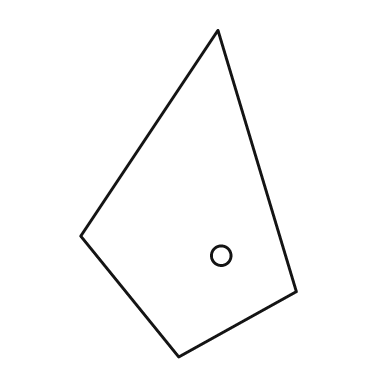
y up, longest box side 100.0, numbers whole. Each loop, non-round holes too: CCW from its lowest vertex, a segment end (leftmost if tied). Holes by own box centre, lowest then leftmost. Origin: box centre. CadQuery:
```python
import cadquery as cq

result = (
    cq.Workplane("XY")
    .moveTo(-3.0, -50.0)
    .lineTo(33.0, -30.0)
    .lineTo(9.0, 50.0)
    .lineTo(-33.0, -13.0)
    .close()
    .moveTo(10.0, -19.0)
    .circle(3.0)
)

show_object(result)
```